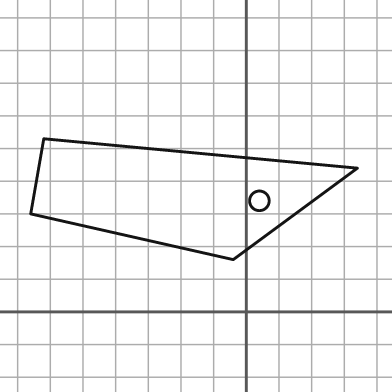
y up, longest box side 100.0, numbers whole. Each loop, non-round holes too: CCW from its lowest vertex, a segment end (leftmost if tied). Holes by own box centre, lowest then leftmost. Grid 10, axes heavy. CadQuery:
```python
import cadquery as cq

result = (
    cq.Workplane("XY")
    .moveTo(-4.0, 16.0)
    .lineTo(34.0, 44.0)
    .lineTo(-62.0, 53.0)
    .lineTo(-66.0, 30.0)
    .close()
    .moveTo(4.0, 34.0)
    .circle(3.0)
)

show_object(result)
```